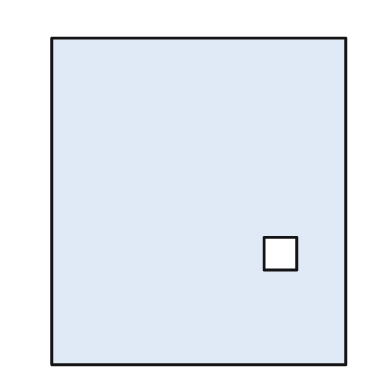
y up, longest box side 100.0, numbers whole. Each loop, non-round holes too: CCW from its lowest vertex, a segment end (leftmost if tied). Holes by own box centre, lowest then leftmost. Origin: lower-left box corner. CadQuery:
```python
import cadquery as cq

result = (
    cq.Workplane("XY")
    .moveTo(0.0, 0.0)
    .lineTo(90.0, 0.0)
    .lineTo(90.0, 100.0)
    .lineTo(0.0, 100.0)
    .close()
    .moveTo(65.0, 29.0)
    .lineTo(75.0, 29.0)
    .lineTo(75.0, 39.0)
    .lineTo(65.0, 39.0)
    .close()
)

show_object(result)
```